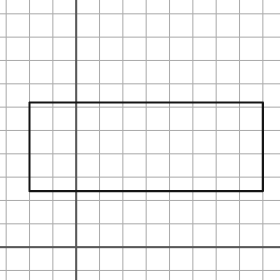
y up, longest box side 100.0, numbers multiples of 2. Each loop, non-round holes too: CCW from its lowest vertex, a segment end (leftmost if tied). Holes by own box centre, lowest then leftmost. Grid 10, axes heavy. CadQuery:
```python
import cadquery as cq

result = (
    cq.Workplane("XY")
    .moveTo(-20.0, 24.0)
    .lineTo(80.0, 24.0)
    .lineTo(80.0, 62.0)
    .lineTo(-20.0, 62.0)
    .close()
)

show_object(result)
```